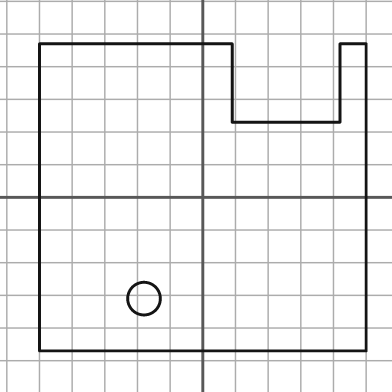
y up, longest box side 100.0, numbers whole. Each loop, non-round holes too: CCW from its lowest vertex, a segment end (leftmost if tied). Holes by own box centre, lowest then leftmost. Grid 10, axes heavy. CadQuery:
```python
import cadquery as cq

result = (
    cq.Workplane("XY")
    .moveTo(-50.0, -47.0)
    .lineTo(50.0, -47.0)
    .lineTo(50.0, 47.0)
    .lineTo(42.0, 47.0)
    .lineTo(42.0, 23.0)
    .lineTo(9.0, 23.0)
    .lineTo(9.0, 47.0)
    .lineTo(-50.0, 47.0)
    .close()
    .moveTo(-18.0, -31.0)
    .circle(5.0)
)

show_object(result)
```